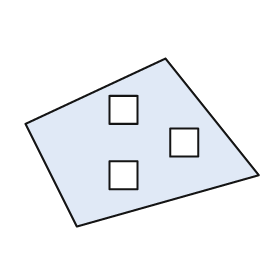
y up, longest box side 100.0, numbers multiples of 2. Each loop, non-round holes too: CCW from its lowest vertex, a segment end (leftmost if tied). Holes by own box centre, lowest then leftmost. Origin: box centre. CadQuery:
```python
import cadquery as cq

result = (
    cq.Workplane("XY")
    .moveTo(-28.0, -36.0)
    .lineTo(50.0, -14.0)
    .lineTo(10.0, 36.0)
    .lineTo(-50.0, 8.0)
    .close()
    .moveTo(-14.0, -20.0)
    .lineTo(-2.0, -20.0)
    .lineTo(-2.0, -8.0)
    .lineTo(-14.0, -8.0)
    .close()
    .moveTo(12.0, -6.0)
    .lineTo(24.0, -6.0)
    .lineTo(24.0, 6.0)
    .lineTo(12.0, 6.0)
    .close()
    .moveTo(-14.0, 8.0)
    .lineTo(-2.0, 8.0)
    .lineTo(-2.0, 20.0)
    .lineTo(-14.0, 20.0)
    .close()
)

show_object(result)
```